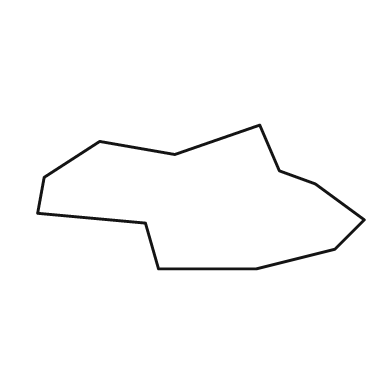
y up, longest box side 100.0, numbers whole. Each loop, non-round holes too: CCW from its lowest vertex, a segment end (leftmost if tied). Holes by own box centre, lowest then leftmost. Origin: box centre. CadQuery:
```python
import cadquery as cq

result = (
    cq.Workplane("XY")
    .moveTo(-13.0, -22.0)
    .lineTo(17.0, -22.0)
    .lineTo(41.0, -16.0)
    .lineTo(50.0, -7.0)
    .lineTo(35.0, 4.0)
    .lineTo(24.0, 8.0)
    .lineTo(18.0, 22.0)
    .lineTo(-8.0, 13.0)
    .lineTo(-31.0, 17.0)
    .lineTo(-48.0, 6.0)
    .lineTo(-50.0, -5.0)
    .lineTo(-17.0, -8.0)
    .close()
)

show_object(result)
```